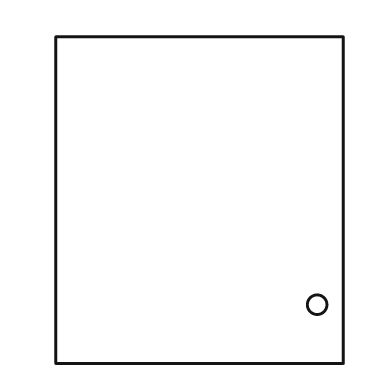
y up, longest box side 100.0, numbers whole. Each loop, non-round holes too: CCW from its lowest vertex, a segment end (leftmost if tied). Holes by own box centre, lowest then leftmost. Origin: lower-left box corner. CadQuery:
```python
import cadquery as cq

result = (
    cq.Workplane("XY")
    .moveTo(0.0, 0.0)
    .lineTo(88.0, 0.0)
    .lineTo(88.0, 100.0)
    .lineTo(0.0, 100.0)
    .close()
    .moveTo(80.0, 18.0)
    .circle(3.0)
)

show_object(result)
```